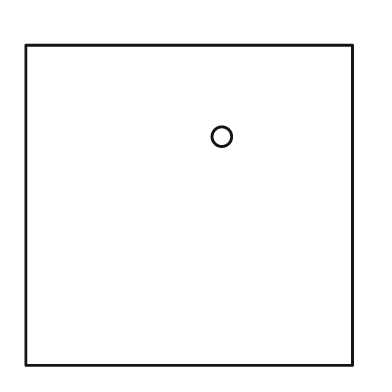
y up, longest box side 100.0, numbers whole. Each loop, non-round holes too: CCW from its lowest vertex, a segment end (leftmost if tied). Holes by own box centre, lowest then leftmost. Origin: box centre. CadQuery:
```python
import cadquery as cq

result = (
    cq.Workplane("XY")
    .moveTo(-50.0, -49.0)
    .lineTo(50.0, -49.0)
    .lineTo(50.0, 49.0)
    .lineTo(-50.0, 49.0)
    .close()
    .moveTo(10.0, 21.0)
    .circle(3.0)
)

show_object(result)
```